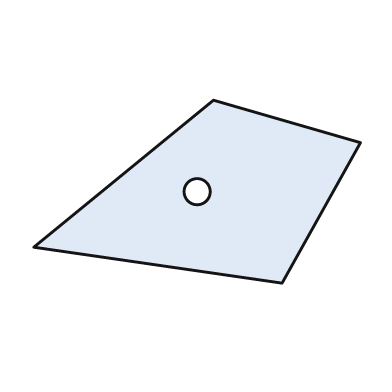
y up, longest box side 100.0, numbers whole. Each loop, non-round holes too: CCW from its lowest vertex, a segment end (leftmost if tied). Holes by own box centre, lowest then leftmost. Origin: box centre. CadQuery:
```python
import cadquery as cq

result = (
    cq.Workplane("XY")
    .moveTo(26.0, -28.0)
    .lineTo(50.0, 15.0)
    .lineTo(5.0, 28.0)
    .lineTo(-50.0, -17.0)
    .close()
    .moveTo(0.0, 0.0)
    .circle(4.0)
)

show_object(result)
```